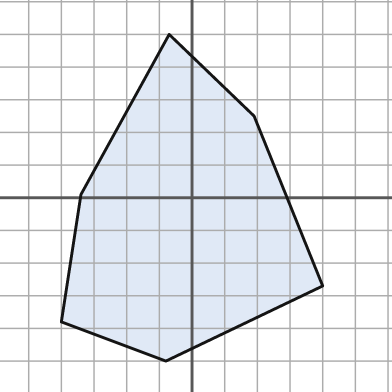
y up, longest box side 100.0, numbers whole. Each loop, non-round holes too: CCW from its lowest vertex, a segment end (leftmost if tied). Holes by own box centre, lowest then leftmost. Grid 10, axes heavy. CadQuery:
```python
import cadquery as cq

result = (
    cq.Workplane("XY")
    .moveTo(-8.0, -50.0)
    .lineTo(40.0, -27.0)
    .lineTo(19.0, 25.0)
    .lineTo(-7.0, 50.0)
    .lineTo(-34.0, 1.0)
    .lineTo(-40.0, -38.0)
    .close()
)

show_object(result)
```